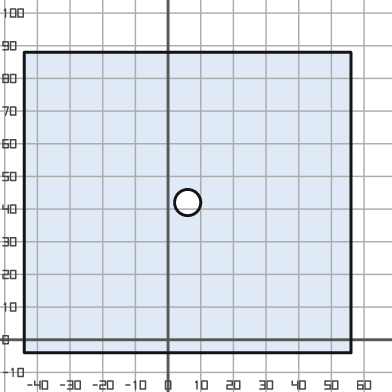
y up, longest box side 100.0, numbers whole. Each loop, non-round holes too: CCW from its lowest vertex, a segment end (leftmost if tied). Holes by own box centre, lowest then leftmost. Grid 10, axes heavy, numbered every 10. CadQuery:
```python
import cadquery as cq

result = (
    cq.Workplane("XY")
    .moveTo(-44.0, -4.0)
    .lineTo(56.0, -4.0)
    .lineTo(56.0, 88.0)
    .lineTo(-44.0, 88.0)
    .close()
    .moveTo(6.0, 42.0)
    .circle(4.0)
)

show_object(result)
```